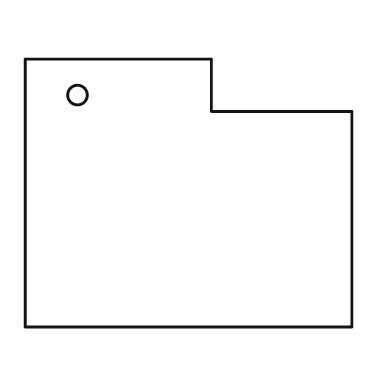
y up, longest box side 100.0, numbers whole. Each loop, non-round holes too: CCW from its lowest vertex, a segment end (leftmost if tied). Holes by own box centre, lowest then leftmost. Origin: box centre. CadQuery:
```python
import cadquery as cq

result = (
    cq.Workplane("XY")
    .moveTo(-50.0, -41.0)
    .lineTo(50.0, -41.0)
    .lineTo(50.0, 25.0)
    .lineTo(7.0, 25.0)
    .lineTo(7.0, 41.0)
    .lineTo(-50.0, 41.0)
    .close()
    .moveTo(-34.0, 30.0)
    .circle(3.0)
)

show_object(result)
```